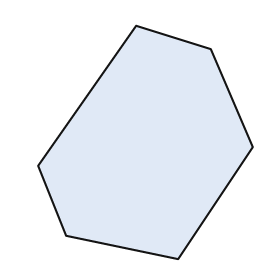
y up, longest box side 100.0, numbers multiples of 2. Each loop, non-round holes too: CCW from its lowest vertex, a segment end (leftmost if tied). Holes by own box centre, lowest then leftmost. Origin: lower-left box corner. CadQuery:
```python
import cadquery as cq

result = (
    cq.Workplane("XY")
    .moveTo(60.0, 0.0)
    .lineTo(92.0, 48.0)
    .lineTo(74.0, 90.0)
    .lineTo(42.0, 100.0)
    .lineTo(0.0, 40.0)
    .lineTo(12.0, 10.0)
    .close()
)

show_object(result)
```